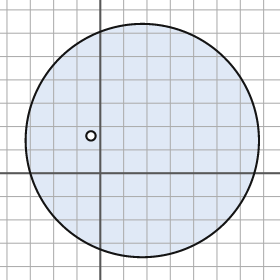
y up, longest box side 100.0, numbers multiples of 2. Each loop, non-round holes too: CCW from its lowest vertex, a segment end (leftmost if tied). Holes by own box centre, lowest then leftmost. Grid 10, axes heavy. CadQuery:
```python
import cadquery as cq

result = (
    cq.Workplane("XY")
    .moveTo(18.0, 14.0)
    .circle(50.0)
    .moveTo(-4.0, 16.0)
    .circle(2.0)
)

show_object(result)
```